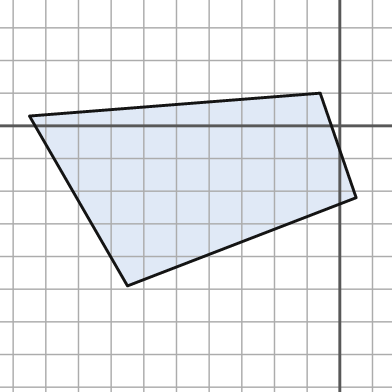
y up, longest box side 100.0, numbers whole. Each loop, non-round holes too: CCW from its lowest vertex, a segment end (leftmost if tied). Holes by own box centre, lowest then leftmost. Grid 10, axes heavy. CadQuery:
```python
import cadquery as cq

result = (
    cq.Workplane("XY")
    .moveTo(-65.0, -49.0)
    .lineTo(5.0, -22.0)
    .lineTo(-6.0, 10.0)
    .lineTo(-95.0, 3.0)
    .close()
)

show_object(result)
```